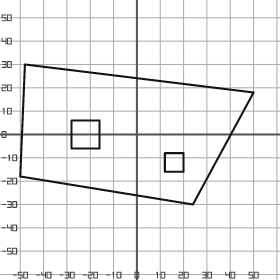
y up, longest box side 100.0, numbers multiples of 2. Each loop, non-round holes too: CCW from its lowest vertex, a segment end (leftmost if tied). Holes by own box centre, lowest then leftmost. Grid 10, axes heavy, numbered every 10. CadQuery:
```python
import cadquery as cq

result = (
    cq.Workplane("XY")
    .moveTo(24.0, -30.0)
    .lineTo(50.0, 18.0)
    .lineTo(-48.0, 30.0)
    .lineTo(-50.0, -18.0)
    .close()
    .moveTo(12.0, -16.0)
    .lineTo(20.0, -16.0)
    .lineTo(20.0, -8.0)
    .lineTo(12.0, -8.0)
    .close()
    .moveTo(-28.0, -6.0)
    .lineTo(-16.0, -6.0)
    .lineTo(-16.0, 6.0)
    .lineTo(-28.0, 6.0)
    .close()
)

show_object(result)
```